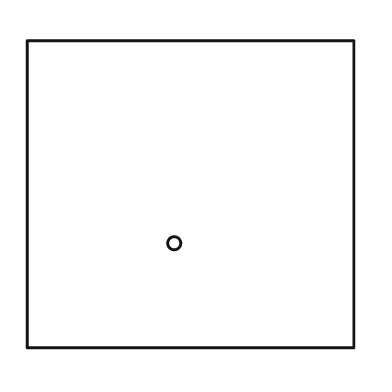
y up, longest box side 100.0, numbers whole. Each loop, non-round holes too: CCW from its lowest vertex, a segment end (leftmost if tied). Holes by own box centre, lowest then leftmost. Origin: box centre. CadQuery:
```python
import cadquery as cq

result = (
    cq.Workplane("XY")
    .moveTo(-50.0, -47.0)
    .lineTo(50.0, -47.0)
    .lineTo(50.0, 47.0)
    .lineTo(-50.0, 47.0)
    .close()
    .moveTo(-5.0, -15.0)
    .circle(2.0)
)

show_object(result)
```